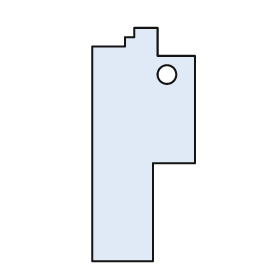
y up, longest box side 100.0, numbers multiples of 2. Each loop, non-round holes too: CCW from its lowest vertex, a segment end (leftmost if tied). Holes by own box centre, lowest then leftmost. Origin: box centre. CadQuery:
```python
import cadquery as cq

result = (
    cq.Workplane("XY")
    .moveTo(-22.0, -50.0)
    .lineTo(4.0, -50.0)
    .lineTo(4.0, -8.0)
    .lineTo(22.0, -8.0)
    .lineTo(22.0, 38.0)
    .lineTo(6.0, 38.0)
    .lineTo(6.0, 50.0)
    .lineTo(-4.0, 50.0)
    .lineTo(-4.0, 46.0)
    .lineTo(-8.0, 46.0)
    .lineTo(-8.0, 42.0)
    .lineTo(-22.0, 42.0)
    .close()
    .moveTo(10.0, 30.0)
    .circle(4.0)
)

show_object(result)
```